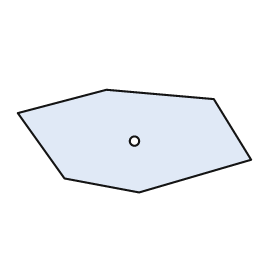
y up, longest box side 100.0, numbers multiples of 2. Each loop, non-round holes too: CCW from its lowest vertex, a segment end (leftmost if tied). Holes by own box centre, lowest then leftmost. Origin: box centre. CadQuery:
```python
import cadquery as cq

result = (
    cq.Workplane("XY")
    .moveTo(2.0, -22.0)
    .lineTo(50.0, -8.0)
    .lineTo(34.0, 18.0)
    .lineTo(-12.0, 22.0)
    .lineTo(-50.0, 12.0)
    .lineTo(-30.0, -16.0)
    .close()
    .moveTo(0.0, 0.0)
    .circle(2.0)
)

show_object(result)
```